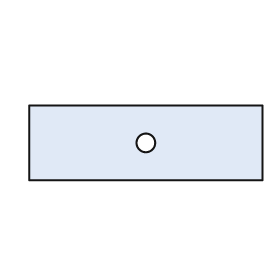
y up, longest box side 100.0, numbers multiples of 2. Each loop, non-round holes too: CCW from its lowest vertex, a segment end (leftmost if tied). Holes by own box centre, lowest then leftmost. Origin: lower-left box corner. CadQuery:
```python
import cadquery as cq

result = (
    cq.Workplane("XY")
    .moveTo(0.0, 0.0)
    .lineTo(100.0, 0.0)
    .lineTo(100.0, 32.0)
    .lineTo(0.0, 32.0)
    .close()
    .moveTo(50.0, 16.0)
    .circle(4.0)
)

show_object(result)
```